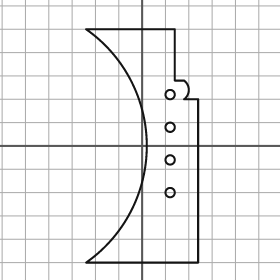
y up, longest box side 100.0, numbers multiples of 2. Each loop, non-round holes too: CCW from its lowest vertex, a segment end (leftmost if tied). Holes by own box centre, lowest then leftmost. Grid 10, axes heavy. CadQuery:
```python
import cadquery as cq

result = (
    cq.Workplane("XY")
    .moveTo(-24.0, -50.0)
    .lineTo(24.0, -50.0)
    .lineTo(24.0, 20.0)
    .lineTo(18.0, 20.0)
    .threePointArc((20.0, 24.0), (18.0, 28.0))
    .lineTo(14.0, 28.0)
    .lineTo(14.0, 50.0)
    .lineTo(-24.0, 50.0)
    .threePointArc((2.0, 0.0), (-24.0, -50.0))
    .close()
    .moveTo(12.0, -20.0)
    .circle(2.0)
    .moveTo(12.0, -6.0)
    .circle(2.0)
    .moveTo(12.0, 8.0)
    .circle(2.0)
    .moveTo(12.0, 22.0)
    .circle(2.0)
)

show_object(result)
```